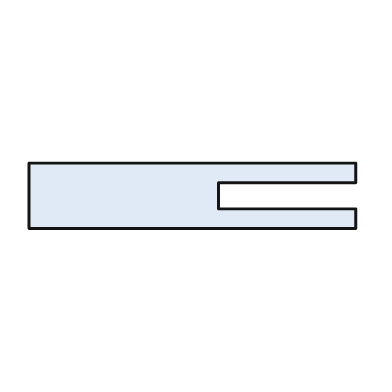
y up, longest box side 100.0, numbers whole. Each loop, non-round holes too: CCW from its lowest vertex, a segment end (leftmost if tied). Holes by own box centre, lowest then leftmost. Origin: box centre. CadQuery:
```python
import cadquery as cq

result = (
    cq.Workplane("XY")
    .moveTo(-50.0, -10.0)
    .lineTo(50.0, -10.0)
    .lineTo(50.0, -4.0)
    .lineTo(8.0, -4.0)
    .lineTo(8.0, 4.0)
    .lineTo(50.0, 4.0)
    .lineTo(50.0, 10.0)
    .lineTo(-50.0, 10.0)
    .close()
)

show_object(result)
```